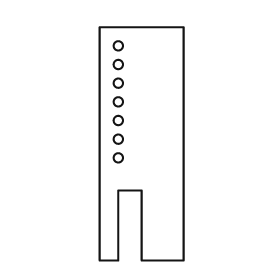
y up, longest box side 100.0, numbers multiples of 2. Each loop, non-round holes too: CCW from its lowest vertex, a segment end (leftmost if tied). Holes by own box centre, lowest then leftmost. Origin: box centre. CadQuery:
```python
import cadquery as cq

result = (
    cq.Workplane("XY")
    .moveTo(-18.0, -50.0)
    .lineTo(-10.0, -50.0)
    .lineTo(-10.0, -20.0)
    .lineTo(0.0, -20.0)
    .lineTo(0.0, -50.0)
    .lineTo(18.0, -50.0)
    .lineTo(18.0, 50.0)
    .lineTo(-18.0, 50.0)
    .close()
    .moveTo(-10.0, -6.0)
    .circle(2.0)
    .moveTo(-10.0, 2.0)
    .circle(2.0)
    .moveTo(-10.0, 10.0)
    .circle(2.0)
    .moveTo(-10.0, 18.0)
    .circle(2.0)
    .moveTo(-10.0, 26.0)
    .circle(2.0)
    .moveTo(-10.0, 34.0)
    .circle(2.0)
    .moveTo(-10.0, 42.0)
    .circle(2.0)
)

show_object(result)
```